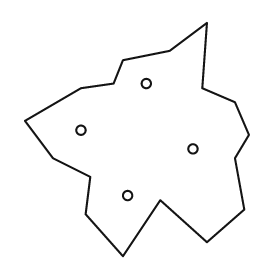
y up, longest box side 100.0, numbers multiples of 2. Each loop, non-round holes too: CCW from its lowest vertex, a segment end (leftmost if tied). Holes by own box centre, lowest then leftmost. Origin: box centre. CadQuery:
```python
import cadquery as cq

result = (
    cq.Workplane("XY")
    .moveTo(-6.0, -50.0)
    .lineTo(10.0, -26.0)
    .lineTo(30.0, -44.0)
    .lineTo(46.0, -30.0)
    .lineTo(42.0, -8.0)
    .lineTo(48.0, 2.0)
    .lineTo(42.0, 16.0)
    .lineTo(28.0, 22.0)
    .lineTo(30.0, 50.0)
    .lineTo(14.0, 38.0)
    .lineTo(-6.0, 34.0)
    .lineTo(-10.0, 24.0)
    .lineTo(-24.0, 22.0)
    .lineTo(-48.0, 8.0)
    .lineTo(-36.0, -8.0)
    .lineTo(-20.0, -16.0)
    .lineTo(-22.0, -32.0)
    .close()
    .moveTo(-4.0, -24.0)
    .circle(2.0)
    .moveTo(24.0, -4.0)
    .circle(2.0)
    .moveTo(-24.0, 4.0)
    .circle(2.0)
    .moveTo(4.0, 24.0)
    .circle(2.0)
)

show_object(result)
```